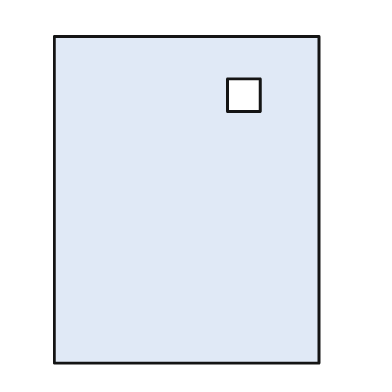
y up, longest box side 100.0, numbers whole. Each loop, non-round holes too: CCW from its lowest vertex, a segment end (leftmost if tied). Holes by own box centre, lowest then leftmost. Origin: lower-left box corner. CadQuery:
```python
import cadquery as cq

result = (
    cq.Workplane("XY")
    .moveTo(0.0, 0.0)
    .lineTo(81.0, 0.0)
    .lineTo(81.0, 100.0)
    .lineTo(0.0, 100.0)
    .close()
    .moveTo(53.0, 77.0)
    .lineTo(63.0, 77.0)
    .lineTo(63.0, 87.0)
    .lineTo(53.0, 87.0)
    .close()
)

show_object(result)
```